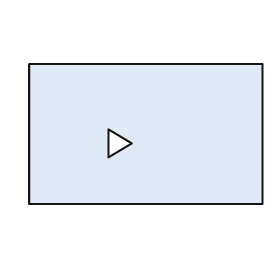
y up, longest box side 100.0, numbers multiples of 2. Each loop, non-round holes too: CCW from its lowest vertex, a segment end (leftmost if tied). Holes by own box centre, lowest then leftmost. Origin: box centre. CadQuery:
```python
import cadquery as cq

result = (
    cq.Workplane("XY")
    .moveTo(-50.0, -30.0)
    .lineTo(50.0, -30.0)
    .lineTo(50.0, 30.0)
    .lineTo(-50.0, 30.0)
    .close()
    .moveTo(-16.0, -10.0)
    .lineTo(-6.0, -4.0)
    .lineTo(-16.0, 2.0)
    .close()
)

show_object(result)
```